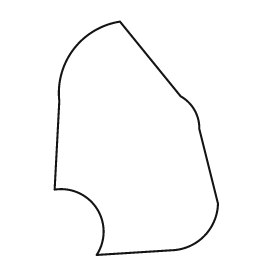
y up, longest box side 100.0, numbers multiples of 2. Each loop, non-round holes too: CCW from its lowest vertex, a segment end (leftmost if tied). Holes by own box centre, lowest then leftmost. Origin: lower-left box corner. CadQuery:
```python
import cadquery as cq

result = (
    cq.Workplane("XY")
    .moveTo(18.0, 0.0)
    .lineTo(50.0, 2.0)
    .threePointArc((64.0, 8.0), (70.0, 22.0))
    .lineTo(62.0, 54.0)
    .threePointArc((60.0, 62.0), (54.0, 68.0))
    .lineTo(28.0, 100.0)
    .threePointArc((8.0, 88.0), (2.0, 66.0))
    .lineTo(0.0, 28.0)
    .threePointArc((18.0, 20.0), (18.0, 0.0))
    .close()
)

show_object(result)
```